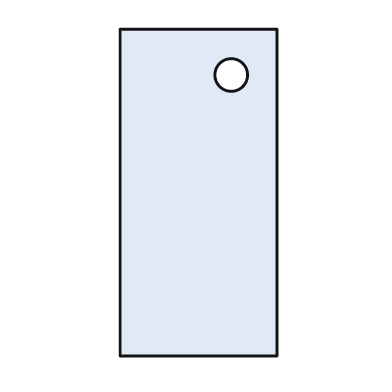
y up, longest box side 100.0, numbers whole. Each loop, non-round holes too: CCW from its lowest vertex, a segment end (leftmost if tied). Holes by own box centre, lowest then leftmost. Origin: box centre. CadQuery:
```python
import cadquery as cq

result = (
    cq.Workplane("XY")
    .moveTo(-24.0, -50.0)
    .lineTo(24.0, -50.0)
    .lineTo(24.0, 50.0)
    .lineTo(-24.0, 50.0)
    .close()
    .moveTo(10.0, 36.0)
    .circle(5.0)
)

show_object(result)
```